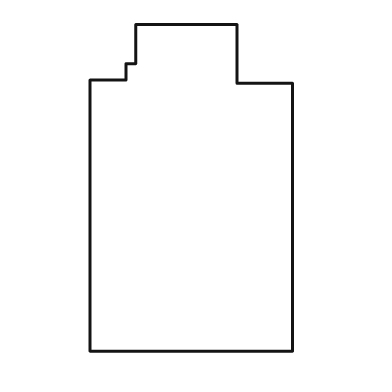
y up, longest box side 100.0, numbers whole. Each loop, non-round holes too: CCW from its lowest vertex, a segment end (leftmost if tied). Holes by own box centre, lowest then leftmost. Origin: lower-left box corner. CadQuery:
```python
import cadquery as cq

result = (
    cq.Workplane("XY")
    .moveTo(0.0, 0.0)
    .lineTo(62.0, 0.0)
    .lineTo(62.0, 82.0)
    .lineTo(45.0, 82.0)
    .lineTo(45.0, 100.0)
    .lineTo(14.0, 100.0)
    .lineTo(14.0, 88.0)
    .lineTo(11.0, 88.0)
    .lineTo(11.0, 83.0)
    .lineTo(0.0, 83.0)
    .close()
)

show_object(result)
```